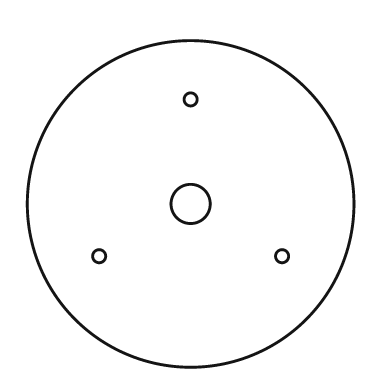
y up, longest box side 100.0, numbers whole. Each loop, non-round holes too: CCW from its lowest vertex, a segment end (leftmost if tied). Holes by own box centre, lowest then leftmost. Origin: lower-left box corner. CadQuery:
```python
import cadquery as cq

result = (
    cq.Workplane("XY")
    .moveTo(50.0, 50.0)
    .circle(50.0)
    .moveTo(22.0, 34.0)
    .circle(2.0)
    .moveTo(78.0, 34.0)
    .circle(2.0)
    .moveTo(50.0, 50.0)
    .circle(6.0)
    .moveTo(50.0, 82.0)
    .circle(2.0)
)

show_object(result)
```